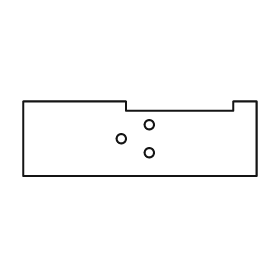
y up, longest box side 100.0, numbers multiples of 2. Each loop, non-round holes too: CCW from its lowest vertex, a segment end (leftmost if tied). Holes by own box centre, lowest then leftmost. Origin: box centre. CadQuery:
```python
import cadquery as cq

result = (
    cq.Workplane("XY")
    .moveTo(-50.0, -16.0)
    .lineTo(50.0, -16.0)
    .lineTo(50.0, 16.0)
    .lineTo(40.0, 16.0)
    .lineTo(40.0, 12.0)
    .lineTo(-6.0, 12.0)
    .lineTo(-6.0, 16.0)
    .lineTo(-50.0, 16.0)
    .close()
    .moveTo(4.0, -6.0)
    .circle(2.0)
    .moveTo(-8.0, 0.0)
    .circle(2.0)
    .moveTo(4.0, 6.0)
    .circle(2.0)
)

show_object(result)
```